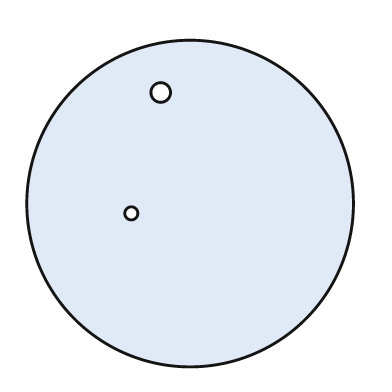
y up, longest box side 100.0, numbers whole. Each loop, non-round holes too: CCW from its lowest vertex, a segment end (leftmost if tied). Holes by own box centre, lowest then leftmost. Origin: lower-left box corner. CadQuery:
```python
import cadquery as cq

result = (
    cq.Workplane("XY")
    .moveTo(50.0, 50.0)
    .circle(50.0)
    .moveTo(32.0, 47.0)
    .circle(2.0)
    .moveTo(41.0, 84.0)
    .circle(3.0)
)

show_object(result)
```